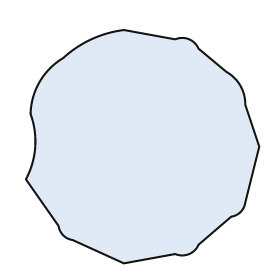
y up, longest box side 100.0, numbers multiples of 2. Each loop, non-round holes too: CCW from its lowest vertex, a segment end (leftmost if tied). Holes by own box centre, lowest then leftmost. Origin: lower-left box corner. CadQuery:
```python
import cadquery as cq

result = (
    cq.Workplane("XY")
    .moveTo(42.0, 0.0)
    .lineTo(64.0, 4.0)
    .threePointArc((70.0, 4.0), (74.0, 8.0))
    .lineTo(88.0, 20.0)
    .threePointArc((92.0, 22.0), (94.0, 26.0))
    .lineTo(100.0, 50.0)
    .lineTo(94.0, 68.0)
    .threePointArc((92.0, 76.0), (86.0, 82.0))
    .lineTo(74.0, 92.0)
    .threePointArc((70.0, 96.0), (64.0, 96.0))
    .lineTo(42.0, 100.0)
    .threePointArc((28.0, 96.0), (16.0, 88.0))
    .threePointArc((6.0, 78.0), (2.0, 64.0))
    .threePointArc((4.0, 50.0), (0.0, 36.0))
    .lineTo(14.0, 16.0)
    .threePointArc((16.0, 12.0), (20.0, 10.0))
    .close()
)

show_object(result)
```